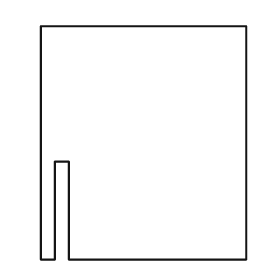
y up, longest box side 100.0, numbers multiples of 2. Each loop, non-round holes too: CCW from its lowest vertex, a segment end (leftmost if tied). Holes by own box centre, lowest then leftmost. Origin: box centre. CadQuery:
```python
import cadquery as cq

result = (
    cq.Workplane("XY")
    .moveTo(-44.0, -50.0)
    .lineTo(-38.0, -50.0)
    .lineTo(-38.0, -8.0)
    .lineTo(-32.0, -8.0)
    .lineTo(-32.0, -50.0)
    .lineTo(44.0, -50.0)
    .lineTo(44.0, 50.0)
    .lineTo(-44.0, 50.0)
    .close()
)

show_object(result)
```